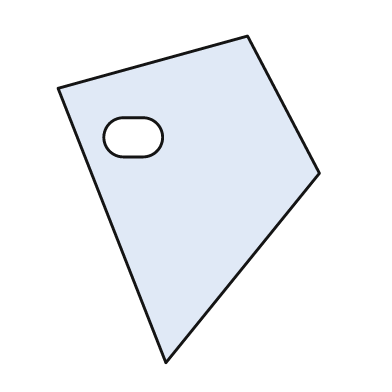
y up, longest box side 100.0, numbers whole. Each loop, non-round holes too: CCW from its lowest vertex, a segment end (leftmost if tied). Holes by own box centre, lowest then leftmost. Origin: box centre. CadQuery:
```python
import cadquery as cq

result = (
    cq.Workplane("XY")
    .moveTo(-7.0, -50.0)
    .lineTo(40.0, 8.0)
    .lineTo(18.0, 50.0)
    .lineTo(-40.0, 34.0)
    .close()
    .moveTo(-20.0, 13.0)
    .lineTo(-14.0, 13.0)
    .threePointArc((-8.0, 19.0), (-14.0, 25.0))
    .lineTo(-20.0, 25.0)
    .threePointArc((-26.0, 19.0), (-20.0, 13.0))
    .close()
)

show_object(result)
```